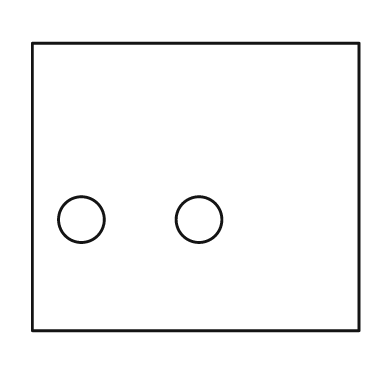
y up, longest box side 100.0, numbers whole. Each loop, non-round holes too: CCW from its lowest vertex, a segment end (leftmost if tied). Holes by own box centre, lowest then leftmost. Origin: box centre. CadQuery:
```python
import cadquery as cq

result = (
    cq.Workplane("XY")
    .moveTo(-50.0, -44.0)
    .lineTo(50.0, -44.0)
    .lineTo(50.0, 44.0)
    .lineTo(-50.0, 44.0)
    .close()
    .moveTo(-35.0, -10.0)
    .circle(7.0)
    .moveTo(1.0, -10.0)
    .circle(7.0)
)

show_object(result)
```